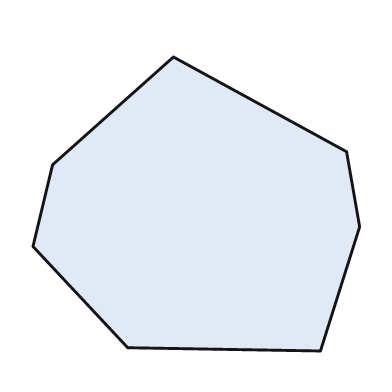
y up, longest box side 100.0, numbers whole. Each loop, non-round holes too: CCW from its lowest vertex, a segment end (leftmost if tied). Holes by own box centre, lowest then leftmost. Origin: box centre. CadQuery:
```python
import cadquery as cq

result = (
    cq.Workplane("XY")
    .moveTo(38.0, -45.0)
    .lineTo(50.0, -7.0)
    .lineTo(46.0, 16.0)
    .lineTo(-7.0, 45.0)
    .lineTo(-44.0, 12.0)
    .lineTo(-50.0, -13.0)
    .lineTo(-21.0, -44.0)
    .close()
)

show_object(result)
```